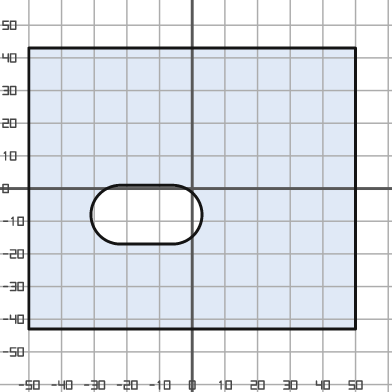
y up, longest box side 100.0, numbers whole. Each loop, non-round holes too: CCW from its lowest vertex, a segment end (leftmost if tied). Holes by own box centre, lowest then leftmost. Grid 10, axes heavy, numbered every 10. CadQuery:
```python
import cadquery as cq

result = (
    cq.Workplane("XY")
    .moveTo(-50.0, -43.0)
    .lineTo(50.0, -43.0)
    .lineTo(50.0, 43.0)
    .lineTo(-50.0, 43.0)
    .close()
    .moveTo(-22.0, -17.0)
    .lineTo(-6.0, -17.0)
    .threePointArc((3.0, -8.0), (-6.0, 1.0))
    .lineTo(-22.0, 1.0)
    .threePointArc((-31.0, -8.0), (-22.0, -17.0))
    .close()
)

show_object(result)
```